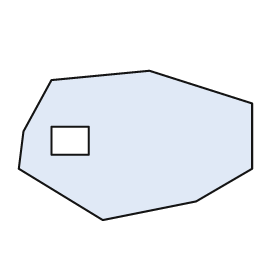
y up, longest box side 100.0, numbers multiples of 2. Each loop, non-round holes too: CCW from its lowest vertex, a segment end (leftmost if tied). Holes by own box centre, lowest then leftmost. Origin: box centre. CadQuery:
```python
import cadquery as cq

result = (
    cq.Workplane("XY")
    .moveTo(-14.0, -32.0)
    .lineTo(26.0, -24.0)
    .lineTo(50.0, -10.0)
    .lineTo(50.0, 18.0)
    .lineTo(6.0, 32.0)
    .lineTo(-36.0, 28.0)
    .lineTo(-48.0, 6.0)
    .lineTo(-50.0, -10.0)
    .close()
    .moveTo(-36.0, -4.0)
    .lineTo(-20.0, -4.0)
    .lineTo(-20.0, 8.0)
    .lineTo(-36.0, 8.0)
    .close()
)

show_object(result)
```